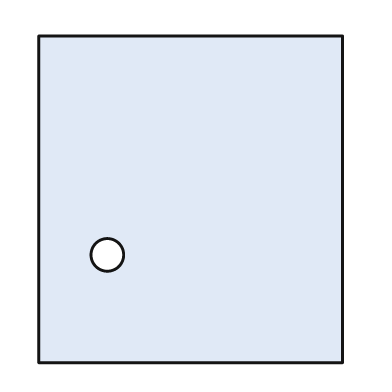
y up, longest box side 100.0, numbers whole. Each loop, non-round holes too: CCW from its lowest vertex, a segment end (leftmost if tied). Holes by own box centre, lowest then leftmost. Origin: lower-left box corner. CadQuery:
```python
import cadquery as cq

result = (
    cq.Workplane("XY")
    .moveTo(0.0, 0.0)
    .lineTo(93.0, 0.0)
    .lineTo(93.0, 100.0)
    .lineTo(0.0, 100.0)
    .close()
    .moveTo(21.0, 33.0)
    .circle(5.0)
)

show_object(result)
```